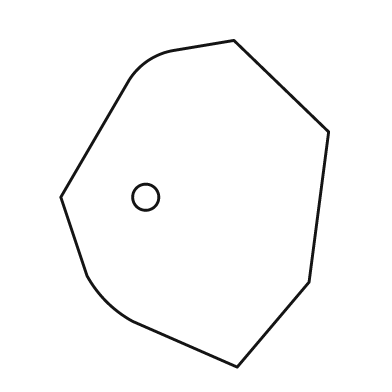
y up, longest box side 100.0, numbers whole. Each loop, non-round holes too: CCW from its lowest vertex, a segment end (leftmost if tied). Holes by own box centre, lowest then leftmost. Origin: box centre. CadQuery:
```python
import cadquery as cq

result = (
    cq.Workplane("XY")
    .moveTo(13.0, -50.0)
    .lineTo(35.0, -24.0)
    .lineTo(41.0, 22.0)
    .lineTo(12.0, 50.0)
    .lineTo(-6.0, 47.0)
    .threePointArc((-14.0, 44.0), (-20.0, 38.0))
    .lineTo(-41.0, 2.0)
    .lineTo(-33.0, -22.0)
    .threePointArc((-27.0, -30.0), (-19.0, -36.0))
    .close()
    .moveTo(-15.0, 2.0)
    .circle(4.0)
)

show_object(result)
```